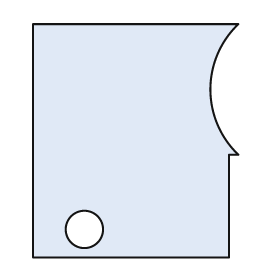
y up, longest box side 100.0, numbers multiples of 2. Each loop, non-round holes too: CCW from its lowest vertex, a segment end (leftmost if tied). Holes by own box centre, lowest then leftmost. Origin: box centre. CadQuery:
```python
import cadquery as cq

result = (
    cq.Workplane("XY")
    .moveTo(-44.0, -50.0)
    .lineTo(40.0, -50.0)
    .lineTo(40.0, -6.0)
    .lineTo(44.0, -6.0)
    .threePointArc((32.0, 22.0), (44.0, 50.0))
    .lineTo(-44.0, 50.0)
    .close()
    .moveTo(-22.0, -38.0)
    .circle(8.0)
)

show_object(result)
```